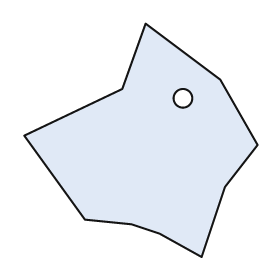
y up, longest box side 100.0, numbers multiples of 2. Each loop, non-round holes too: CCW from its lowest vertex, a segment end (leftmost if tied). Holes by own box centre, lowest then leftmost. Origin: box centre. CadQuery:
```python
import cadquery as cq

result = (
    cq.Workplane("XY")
    .moveTo(26.0, -50.0)
    .lineTo(36.0, -20.0)
    .lineTo(50.0, -2.0)
    .lineTo(34.0, 26.0)
    .lineTo(2.0, 50.0)
    .lineTo(-8.0, 22.0)
    .lineTo(-50.0, 2.0)
    .lineTo(-24.0, -34.0)
    .lineTo(-4.0, -36.0)
    .lineTo(8.0, -40.0)
    .close()
    .moveTo(18.0, 18.0)
    .circle(4.0)
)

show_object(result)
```